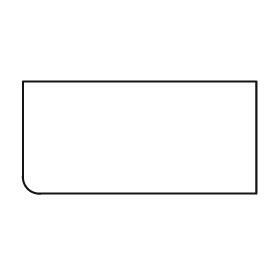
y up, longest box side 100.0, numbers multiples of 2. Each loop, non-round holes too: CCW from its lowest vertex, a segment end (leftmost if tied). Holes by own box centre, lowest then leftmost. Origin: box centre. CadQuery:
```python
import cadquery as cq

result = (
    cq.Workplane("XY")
    .moveTo(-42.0, -24.0)
    .lineTo(50.0, -24.0)
    .lineTo(50.0, 24.0)
    .lineTo(-50.0, 24.0)
    .lineTo(-50.0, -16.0)
    .threePointArc((-48.0, -22.0), (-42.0, -24.0))
    .close()
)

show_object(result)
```